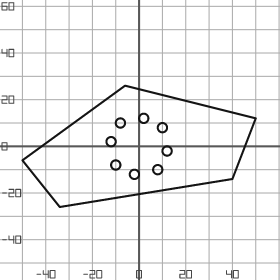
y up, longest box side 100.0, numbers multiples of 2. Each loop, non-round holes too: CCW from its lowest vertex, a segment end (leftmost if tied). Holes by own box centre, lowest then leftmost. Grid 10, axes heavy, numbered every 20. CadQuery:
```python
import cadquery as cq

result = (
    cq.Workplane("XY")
    .moveTo(-34.0, -26.0)
    .lineTo(40.0, -14.0)
    .lineTo(50.0, 12.0)
    .lineTo(-6.0, 26.0)
    .lineTo(-50.0, -6.0)
    .close()
    .moveTo(-2.0, -12.0)
    .circle(2.0)
    .moveTo(8.0, -10.0)
    .circle(2.0)
    .moveTo(-10.0, -8.0)
    .circle(2.0)
    .moveTo(12.0, -2.0)
    .circle(2.0)
    .moveTo(-12.0, 2.0)
    .circle(2.0)
    .moveTo(10.0, 8.0)
    .circle(2.0)
    .moveTo(-8.0, 10.0)
    .circle(2.0)
    .moveTo(2.0, 12.0)
    .circle(2.0)
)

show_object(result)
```